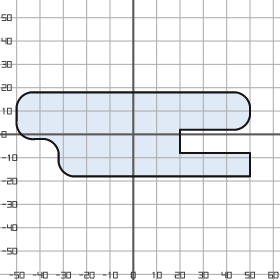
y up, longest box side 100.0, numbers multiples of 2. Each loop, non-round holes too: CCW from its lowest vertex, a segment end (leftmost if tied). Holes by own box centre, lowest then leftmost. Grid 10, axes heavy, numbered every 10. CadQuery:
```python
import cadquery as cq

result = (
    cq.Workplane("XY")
    .moveTo(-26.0, -18.0)
    .lineTo(50.0, -18.0)
    .lineTo(50.0, -8.0)
    .lineTo(20.0, -8.0)
    .lineTo(20.0, 2.0)
    .lineTo(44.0, 2.0)
    .threePointArc((48.0, 4.0), (50.0, 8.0))
    .lineTo(50.0, 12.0)
    .threePointArc((48.0, 16.0), (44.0, 18.0))
    .lineTo(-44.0, 18.0)
    .threePointArc((-48.0, 16.0), (-50.0, 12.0))
    .lineTo(-50.0, 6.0)
    .threePointArc((-48.0, 0.0), (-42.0, -2.0))
    .lineTo(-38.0, -2.0)
    .threePointArc((-34.0, -4.0), (-32.0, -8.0))
    .lineTo(-32.0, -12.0)
    .threePointArc((-30.0, -16.0), (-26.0, -18.0))
    .close()
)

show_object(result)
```